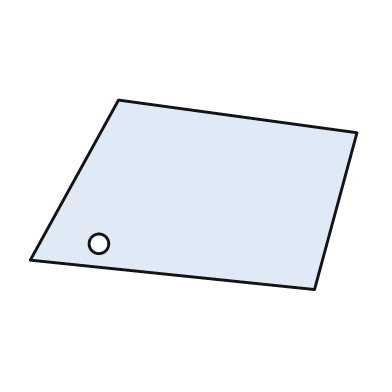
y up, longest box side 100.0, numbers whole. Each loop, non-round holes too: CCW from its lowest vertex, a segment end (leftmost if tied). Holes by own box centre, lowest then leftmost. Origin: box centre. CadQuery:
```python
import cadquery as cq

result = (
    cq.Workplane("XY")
    .moveTo(37.0, -29.0)
    .lineTo(50.0, 19.0)
    .lineTo(-23.0, 29.0)
    .lineTo(-50.0, -20.0)
    .close()
    .moveTo(-29.0, -15.0)
    .circle(3.0)
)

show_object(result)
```